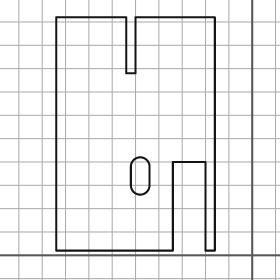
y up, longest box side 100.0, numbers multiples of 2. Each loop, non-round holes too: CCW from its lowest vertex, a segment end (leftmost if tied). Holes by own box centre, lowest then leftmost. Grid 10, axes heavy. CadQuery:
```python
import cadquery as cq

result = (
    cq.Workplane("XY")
    .moveTo(-84.0, 2.0)
    .lineTo(-34.0, 2.0)
    .lineTo(-34.0, 40.0)
    .lineTo(-20.0, 40.0)
    .lineTo(-20.0, 2.0)
    .lineTo(-16.0, 2.0)
    .lineTo(-16.0, 102.0)
    .lineTo(-50.0, 102.0)
    .lineTo(-50.0, 78.0)
    .lineTo(-54.0, 78.0)
    .lineTo(-54.0, 102.0)
    .lineTo(-84.0, 102.0)
    .close()
    .moveTo(-52.0, 30.0)
    .threePointArc((-48.0, 26.0), (-44.0, 30.0))
    .lineTo(-44.0, 38.0)
    .threePointArc((-48.0, 42.0), (-52.0, 38.0))
    .close()
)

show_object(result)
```